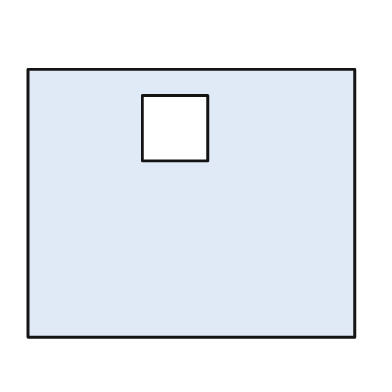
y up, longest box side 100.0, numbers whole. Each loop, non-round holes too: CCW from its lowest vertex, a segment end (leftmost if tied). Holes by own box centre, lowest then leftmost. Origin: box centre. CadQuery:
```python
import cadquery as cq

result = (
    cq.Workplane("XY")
    .moveTo(-50.0, -41.0)
    .lineTo(50.0, -41.0)
    .lineTo(50.0, 41.0)
    .lineTo(-50.0, 41.0)
    .close()
    .moveTo(-15.0, 13.0)
    .lineTo(5.0, 13.0)
    .lineTo(5.0, 33.0)
    .lineTo(-15.0, 33.0)
    .close()
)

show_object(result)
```